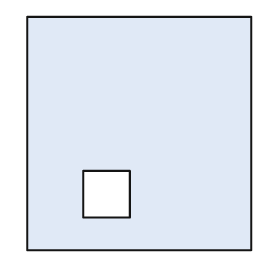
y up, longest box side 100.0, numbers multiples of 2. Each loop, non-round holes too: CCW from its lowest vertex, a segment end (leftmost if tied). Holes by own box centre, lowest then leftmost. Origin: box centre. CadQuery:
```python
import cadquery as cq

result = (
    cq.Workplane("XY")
    .moveTo(-48.0, -50.0)
    .lineTo(48.0, -50.0)
    .lineTo(48.0, 50.0)
    .lineTo(-48.0, 50.0)
    .close()
    .moveTo(-24.0, -36.0)
    .lineTo(-4.0, -36.0)
    .lineTo(-4.0, -16.0)
    .lineTo(-24.0, -16.0)
    .close()
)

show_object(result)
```